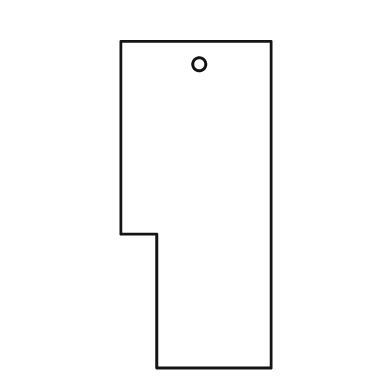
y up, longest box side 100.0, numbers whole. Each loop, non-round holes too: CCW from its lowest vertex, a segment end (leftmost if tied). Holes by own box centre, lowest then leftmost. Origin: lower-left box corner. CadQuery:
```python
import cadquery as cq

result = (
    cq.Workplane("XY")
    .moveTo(11.0, 0.0)
    .lineTo(46.0, 0.0)
    .lineTo(46.0, 100.0)
    .lineTo(0.0, 100.0)
    .lineTo(0.0, 41.0)
    .lineTo(11.0, 41.0)
    .close()
    .moveTo(24.0, 93.0)
    .circle(2.0)
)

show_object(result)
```